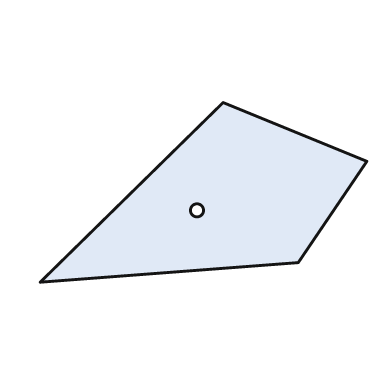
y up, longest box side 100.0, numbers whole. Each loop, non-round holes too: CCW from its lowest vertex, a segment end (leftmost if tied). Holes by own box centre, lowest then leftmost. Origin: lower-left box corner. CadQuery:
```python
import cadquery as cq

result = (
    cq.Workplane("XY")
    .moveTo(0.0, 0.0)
    .lineTo(79.0, 6.0)
    .lineTo(100.0, 37.0)
    .lineTo(56.0, 55.0)
    .close()
    .moveTo(48.0, 22.0)
    .circle(2.0)
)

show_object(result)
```